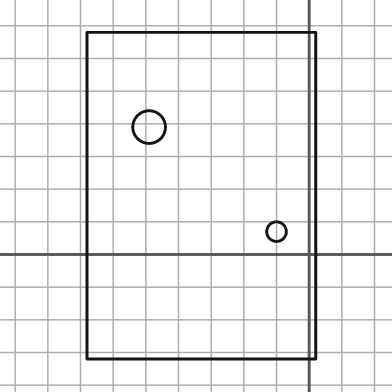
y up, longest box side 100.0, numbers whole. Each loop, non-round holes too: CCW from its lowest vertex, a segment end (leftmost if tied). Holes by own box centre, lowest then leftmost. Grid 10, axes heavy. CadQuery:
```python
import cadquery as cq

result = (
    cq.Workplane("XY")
    .moveTo(-68.0, -32.0)
    .lineTo(2.0, -32.0)
    .lineTo(2.0, 68.0)
    .lineTo(-68.0, 68.0)
    .close()
    .moveTo(-10.0, 7.0)
    .circle(3.0)
    .moveTo(-49.0, 39.0)
    .circle(5.0)
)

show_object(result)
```